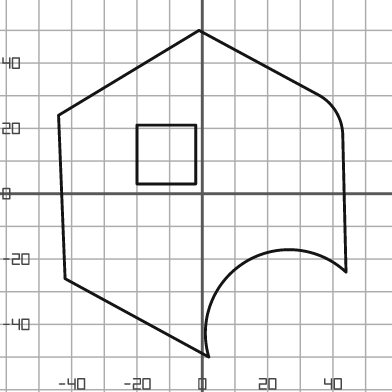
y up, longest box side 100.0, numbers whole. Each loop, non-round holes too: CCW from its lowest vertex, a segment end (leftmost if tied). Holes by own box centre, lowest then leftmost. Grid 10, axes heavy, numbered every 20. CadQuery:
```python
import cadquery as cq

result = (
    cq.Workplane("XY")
    .moveTo(2.0, -50.0)
    .threePointArc((13.0, -21.0), (44.0, -24.0))
    .lineTo(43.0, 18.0)
    .threePointArc((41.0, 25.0), (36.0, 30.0))
    .lineTo(-1.0, 50.0)
    .lineTo(-44.0, 24.0)
    .lineTo(-42.0, -26.0)
    .close()
    .moveTo(-20.0, 3.0)
    .lineTo(-2.0, 3.0)
    .lineTo(-2.0, 21.0)
    .lineTo(-20.0, 21.0)
    .close()
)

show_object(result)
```